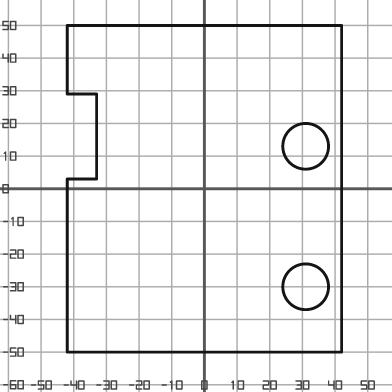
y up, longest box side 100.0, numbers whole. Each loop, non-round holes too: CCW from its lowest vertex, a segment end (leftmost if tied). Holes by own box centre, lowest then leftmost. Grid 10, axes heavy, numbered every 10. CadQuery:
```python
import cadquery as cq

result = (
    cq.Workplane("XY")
    .moveTo(-42.0, -50.0)
    .lineTo(42.0, -50.0)
    .lineTo(42.0, 50.0)
    .lineTo(-42.0, 50.0)
    .lineTo(-42.0, 29.0)
    .lineTo(-33.0, 29.0)
    .lineTo(-33.0, 3.0)
    .lineTo(-42.0, 3.0)
    .close()
    .moveTo(31.0, -30.0)
    .circle(7.0)
    .moveTo(31.0, 13.0)
    .circle(7.0)
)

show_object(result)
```